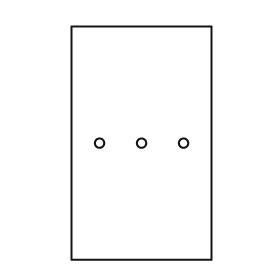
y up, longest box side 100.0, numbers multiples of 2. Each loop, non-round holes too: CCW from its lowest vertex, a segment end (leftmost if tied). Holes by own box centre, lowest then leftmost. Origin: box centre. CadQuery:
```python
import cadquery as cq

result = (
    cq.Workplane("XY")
    .moveTo(-30.0, -50.0)
    .lineTo(30.0, -50.0)
    .lineTo(30.0, 50.0)
    .lineTo(-30.0, 50.0)
    .close()
    .moveTo(-18.0, 0.0)
    .circle(2.0)
    .moveTo(0.0, 0.0)
    .circle(2.0)
    .moveTo(18.0, 0.0)
    .circle(2.0)
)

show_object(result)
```